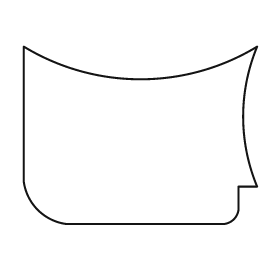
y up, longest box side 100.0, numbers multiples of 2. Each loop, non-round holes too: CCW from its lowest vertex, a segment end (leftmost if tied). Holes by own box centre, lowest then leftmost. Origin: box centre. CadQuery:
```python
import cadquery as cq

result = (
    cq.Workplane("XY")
    .moveTo(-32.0, -38.0)
    .lineTo(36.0, -38.0)
    .threePointArc((40.0, -36.0), (42.0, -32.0))
    .lineTo(42.0, -22.0)
    .lineTo(50.0, -22.0)
    .threePointArc((44.0, 8.0), (50.0, 38.0))
    .threePointArc((0.0, 24.0), (-50.0, 38.0))
    .lineTo(-50.0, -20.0)
    .threePointArc((-44.0, -32.0), (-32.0, -38.0))
    .close()
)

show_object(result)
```